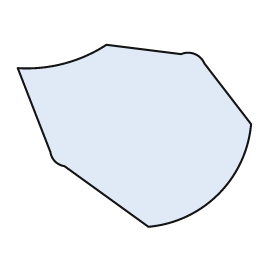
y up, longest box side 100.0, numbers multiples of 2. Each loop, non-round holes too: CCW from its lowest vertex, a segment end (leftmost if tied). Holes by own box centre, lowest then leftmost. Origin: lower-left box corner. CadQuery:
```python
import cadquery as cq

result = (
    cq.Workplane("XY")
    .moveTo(56.0, 0.0)
    .threePointArc((86.0, 14.0), (100.0, 44.0))
    .lineTo(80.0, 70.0)
    .threePointArc((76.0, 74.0), (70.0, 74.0))
    .lineTo(38.0, 78.0)
    .threePointArc((20.0, 70.0), (0.0, 68.0))
    .lineTo(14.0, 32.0)
    .threePointArc((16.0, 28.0), (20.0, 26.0))
    .close()
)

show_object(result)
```